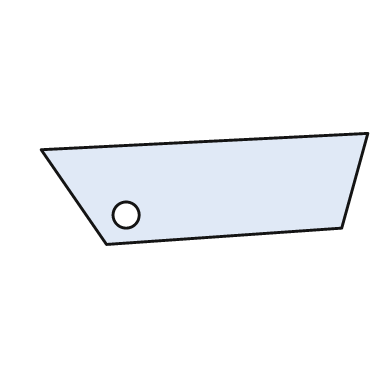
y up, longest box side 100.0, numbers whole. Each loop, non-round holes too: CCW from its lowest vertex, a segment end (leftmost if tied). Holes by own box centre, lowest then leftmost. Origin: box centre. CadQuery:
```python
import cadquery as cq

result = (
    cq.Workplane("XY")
    .moveTo(-30.0, -17.0)
    .lineTo(42.0, -12.0)
    .lineTo(50.0, 17.0)
    .lineTo(-50.0, 12.0)
    .close()
    .moveTo(-24.0, -8.0)
    .circle(4.0)
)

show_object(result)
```